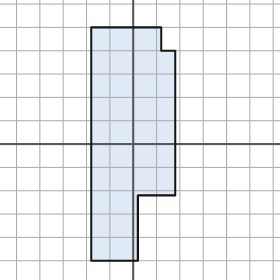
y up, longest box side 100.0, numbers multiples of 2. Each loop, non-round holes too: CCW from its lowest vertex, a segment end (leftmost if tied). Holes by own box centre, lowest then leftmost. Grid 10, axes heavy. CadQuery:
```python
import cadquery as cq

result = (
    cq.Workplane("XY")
    .moveTo(-18.0, -50.0)
    .lineTo(2.0, -50.0)
    .lineTo(2.0, -22.0)
    .lineTo(18.0, -22.0)
    .lineTo(18.0, 40.0)
    .lineTo(12.0, 40.0)
    .lineTo(12.0, 50.0)
    .lineTo(-18.0, 50.0)
    .close()
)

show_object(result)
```